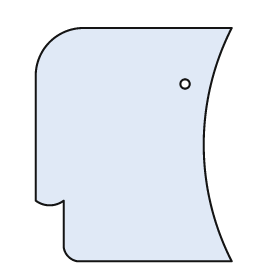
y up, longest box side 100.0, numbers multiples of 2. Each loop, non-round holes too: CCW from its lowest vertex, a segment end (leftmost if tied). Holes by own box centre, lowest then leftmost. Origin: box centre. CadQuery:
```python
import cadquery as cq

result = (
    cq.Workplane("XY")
    .moveTo(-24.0, -50.0)
    .lineTo(42.0, -50.0)
    .threePointArc((30.0, 0.0), (42.0, 50.0))
    .lineTo(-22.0, 50.0)
    .threePointArc((-36.0, 44.0), (-42.0, 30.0))
    .lineTo(-42.0, -24.0)
    .threePointArc((-36.0, -26.0), (-30.0, -24.0))
    .lineTo(-30.0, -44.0)
    .threePointArc((-28.0, -48.0), (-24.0, -50.0))
    .close()
    .moveTo(22.0, 26.0)
    .circle(2.0)
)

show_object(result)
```